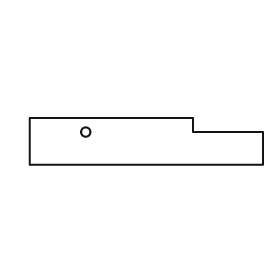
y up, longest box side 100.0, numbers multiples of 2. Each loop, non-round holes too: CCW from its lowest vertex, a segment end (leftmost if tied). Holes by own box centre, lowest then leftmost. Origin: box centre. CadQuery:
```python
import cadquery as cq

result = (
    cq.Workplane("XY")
    .moveTo(-50.0, -10.0)
    .lineTo(50.0, -10.0)
    .lineTo(50.0, 4.0)
    .lineTo(20.0, 4.0)
    .lineTo(20.0, 10.0)
    .lineTo(-50.0, 10.0)
    .close()
    .moveTo(-26.0, 4.0)
    .circle(2.0)
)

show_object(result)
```